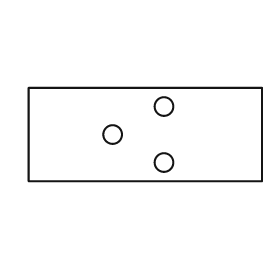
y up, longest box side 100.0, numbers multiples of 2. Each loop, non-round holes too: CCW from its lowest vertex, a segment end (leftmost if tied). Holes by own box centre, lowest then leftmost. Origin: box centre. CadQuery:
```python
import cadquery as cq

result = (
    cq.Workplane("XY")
    .moveTo(-50.0, -20.0)
    .lineTo(50.0, -20.0)
    .lineTo(50.0, 20.0)
    .lineTo(-50.0, 20.0)
    .close()
    .moveTo(8.0, -12.0)
    .circle(4.0)
    .moveTo(-14.0, 0.0)
    .circle(4.0)
    .moveTo(8.0, 12.0)
    .circle(4.0)
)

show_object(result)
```